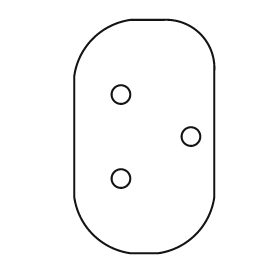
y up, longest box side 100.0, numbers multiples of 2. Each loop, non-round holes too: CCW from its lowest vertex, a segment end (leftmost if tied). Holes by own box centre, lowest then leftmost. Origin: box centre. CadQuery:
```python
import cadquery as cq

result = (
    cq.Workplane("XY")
    .moveTo(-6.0, -50.0)
    .lineTo(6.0, -50.0)
    .threePointArc((22.0, -42.0), (30.0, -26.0))
    .lineTo(30.0, 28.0)
    .threePointArc((24.0, 44.0), (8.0, 50.0))
    .lineTo(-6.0, 50.0)
    .threePointArc((-22.0, 42.0), (-30.0, 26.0))
    .lineTo(-30.0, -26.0)
    .threePointArc((-22.0, -42.0), (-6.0, -50.0))
    .close()
    .moveTo(-10.0, -18.0)
    .circle(4.0)
    .moveTo(20.0, 0.0)
    .circle(4.0)
    .moveTo(-10.0, 18.0)
    .circle(4.0)
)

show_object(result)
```